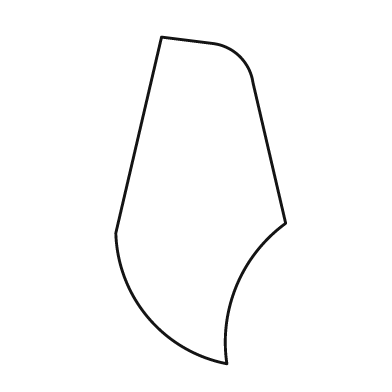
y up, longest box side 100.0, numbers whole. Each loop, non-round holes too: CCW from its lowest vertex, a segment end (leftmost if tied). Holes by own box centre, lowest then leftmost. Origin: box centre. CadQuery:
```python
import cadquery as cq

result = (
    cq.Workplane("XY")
    .moveTo(8.0, -50.0)
    .threePointArc((11.0, -26.0), (26.0, -7.0))
    .lineTo(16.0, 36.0)
    .threePointArc((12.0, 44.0), (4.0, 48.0))
    .lineTo(-12.0, 50.0)
    .lineTo(-26.0, -10.0)
    .threePointArc((-16.0, -36.0), (8.0, -50.0))
    .close()
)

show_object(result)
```